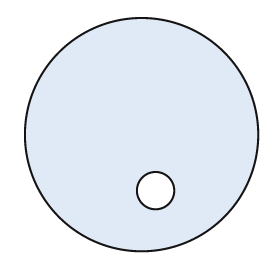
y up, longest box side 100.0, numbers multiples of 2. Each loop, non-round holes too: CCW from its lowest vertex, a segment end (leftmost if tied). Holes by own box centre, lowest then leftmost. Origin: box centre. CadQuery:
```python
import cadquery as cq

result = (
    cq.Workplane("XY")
    .moveTo(0.0, 0.0)
    .circle(50.0)
    .moveTo(6.0, -24.0)
    .circle(8.0)
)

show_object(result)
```